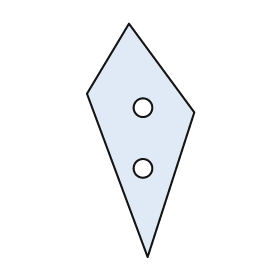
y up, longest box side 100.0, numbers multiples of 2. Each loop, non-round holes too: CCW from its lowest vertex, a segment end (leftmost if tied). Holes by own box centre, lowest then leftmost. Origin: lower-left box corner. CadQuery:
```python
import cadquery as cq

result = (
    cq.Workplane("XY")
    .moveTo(26.0, 0.0)
    .lineTo(46.0, 62.0)
    .lineTo(18.0, 100.0)
    .lineTo(0.0, 70.0)
    .close()
    .moveTo(24.0, 38.0)
    .circle(4.0)
    .moveTo(24.0, 64.0)
    .circle(4.0)
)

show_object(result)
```